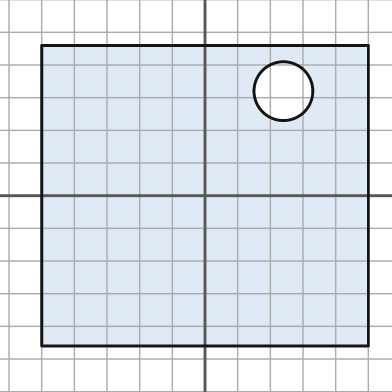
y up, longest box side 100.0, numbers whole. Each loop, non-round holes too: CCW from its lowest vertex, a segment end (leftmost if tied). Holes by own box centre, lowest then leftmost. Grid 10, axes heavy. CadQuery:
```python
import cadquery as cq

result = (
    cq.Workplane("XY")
    .moveTo(-50.0, -46.0)
    .lineTo(50.0, -46.0)
    .lineTo(50.0, 46.0)
    .lineTo(-50.0, 46.0)
    .close()
    .moveTo(24.0, 32.0)
    .circle(9.0)
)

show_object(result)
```